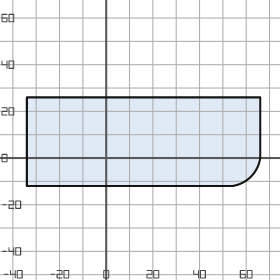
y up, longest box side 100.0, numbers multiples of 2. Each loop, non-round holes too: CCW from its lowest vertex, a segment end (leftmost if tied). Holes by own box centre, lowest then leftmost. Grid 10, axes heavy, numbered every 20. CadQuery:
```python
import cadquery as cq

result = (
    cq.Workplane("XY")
    .moveTo(-34.0, -12.0)
    .lineTo(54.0, -12.0)
    .threePointArc((62.0, -8.0), (66.0, 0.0))
    .lineTo(66.0, 26.0)
    .lineTo(-34.0, 26.0)
    .close()
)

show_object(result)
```